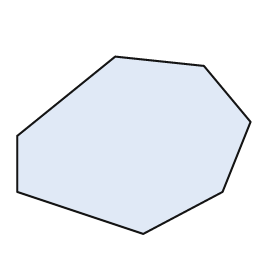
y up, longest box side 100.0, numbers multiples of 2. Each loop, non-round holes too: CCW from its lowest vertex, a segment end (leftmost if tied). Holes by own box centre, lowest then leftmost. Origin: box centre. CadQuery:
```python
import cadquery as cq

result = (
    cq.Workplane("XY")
    .moveTo(4.0, -38.0)
    .lineTo(38.0, -20.0)
    .lineTo(50.0, 10.0)
    .lineTo(30.0, 34.0)
    .lineTo(-8.0, 38.0)
    .lineTo(-50.0, 4.0)
    .lineTo(-50.0, -20.0)
    .close()
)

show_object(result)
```